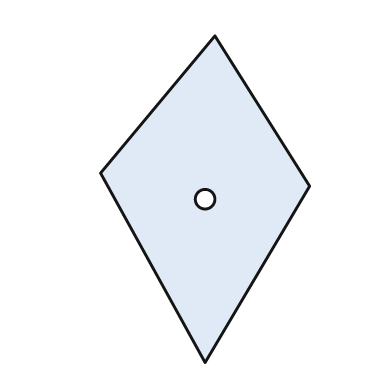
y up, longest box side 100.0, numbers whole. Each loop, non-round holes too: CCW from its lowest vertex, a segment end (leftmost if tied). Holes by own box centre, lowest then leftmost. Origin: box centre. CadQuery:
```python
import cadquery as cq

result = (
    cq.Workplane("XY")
    .moveTo(0.0, -50.0)
    .lineTo(32.0, 4.0)
    .lineTo(3.0, 50.0)
    .lineTo(-32.0, 8.0)
    .close()
    .moveTo(0.0, 0.0)
    .circle(3.0)
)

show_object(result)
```